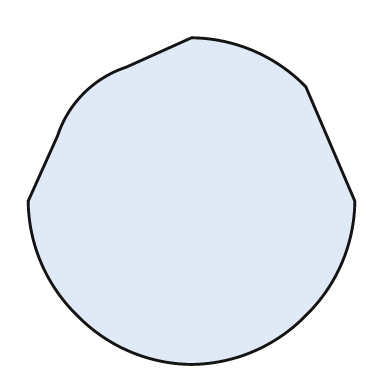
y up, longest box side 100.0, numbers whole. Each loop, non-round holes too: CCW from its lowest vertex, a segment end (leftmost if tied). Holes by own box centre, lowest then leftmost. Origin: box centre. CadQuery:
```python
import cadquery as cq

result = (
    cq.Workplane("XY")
    .moveTo(0.0, -50.0)
    .threePointArc((19.0, -46.0), (35.0, -35.0))
    .threePointArc((46.0, -19.0), (50.0, 0.0))
    .lineTo(35.0, 35.0)
    .threePointArc((19.0, 46.0), (0.0, 50.0))
    .lineTo(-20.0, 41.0)
    .threePointArc((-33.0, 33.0), (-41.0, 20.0))
    .lineTo(-50.0, 0.0)
    .threePointArc((-46.0, -19.0), (-35.0, -35.0))
    .threePointArc((-19.0, -46.0), (0.0, -50.0))
    .close()
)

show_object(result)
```